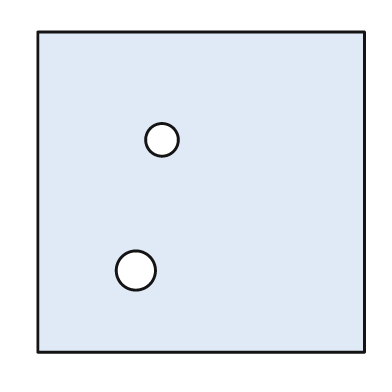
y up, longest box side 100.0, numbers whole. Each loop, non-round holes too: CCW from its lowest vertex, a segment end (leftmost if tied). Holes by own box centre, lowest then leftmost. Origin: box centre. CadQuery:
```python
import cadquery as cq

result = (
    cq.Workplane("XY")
    .moveTo(-50.0, -49.0)
    .lineTo(50.0, -49.0)
    .lineTo(50.0, 49.0)
    .lineTo(-50.0, 49.0)
    .close()
    .moveTo(-20.0, -24.0)
    .circle(6.0)
    .moveTo(-12.0, 16.0)
    .circle(5.0)
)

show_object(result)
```